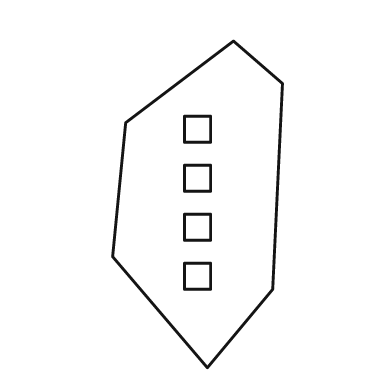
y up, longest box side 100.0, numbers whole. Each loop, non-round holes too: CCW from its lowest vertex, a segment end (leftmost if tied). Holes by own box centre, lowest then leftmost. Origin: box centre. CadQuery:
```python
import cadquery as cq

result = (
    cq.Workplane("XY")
    .moveTo(3.0, -50.0)
    .lineTo(23.0, -26.0)
    .lineTo(26.0, 37.0)
    .lineTo(11.0, 50.0)
    .lineTo(-22.0, 25.0)
    .lineTo(-26.0, -16.0)
    .close()
    .moveTo(-4.0, -26.0)
    .lineTo(4.0, -26.0)
    .lineTo(4.0, -18.0)
    .lineTo(-4.0, -18.0)
    .close()
    .moveTo(-4.0, -11.0)
    .lineTo(4.0, -11.0)
    .lineTo(4.0, -3.0)
    .lineTo(-4.0, -3.0)
    .close()
    .moveTo(-4.0, 4.0)
    .lineTo(4.0, 4.0)
    .lineTo(4.0, 12.0)
    .lineTo(-4.0, 12.0)
    .close()
    .moveTo(-4.0, 19.0)
    .lineTo(4.0, 19.0)
    .lineTo(4.0, 27.0)
    .lineTo(-4.0, 27.0)
    .close()
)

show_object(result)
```